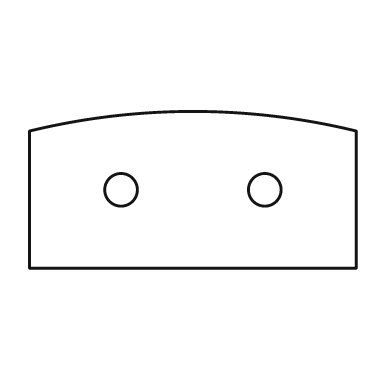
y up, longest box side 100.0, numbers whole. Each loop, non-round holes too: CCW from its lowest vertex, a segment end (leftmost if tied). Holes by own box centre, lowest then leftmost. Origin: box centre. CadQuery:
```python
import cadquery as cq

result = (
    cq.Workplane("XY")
    .moveTo(-50.0, -24.0)
    .lineTo(50.0, -24.0)
    .lineTo(50.0, 18.0)
    .threePointArc((0.0, 24.0), (-50.0, 18.0))
    .close()
    .moveTo(-22.0, 0.0)
    .circle(5.0)
    .moveTo(22.0, 0.0)
    .circle(5.0)
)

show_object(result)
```